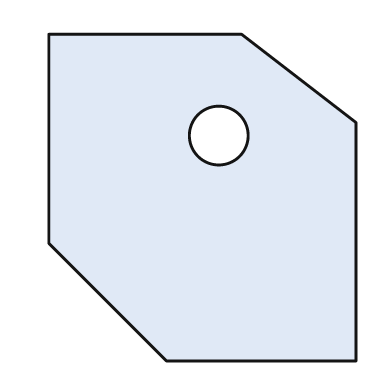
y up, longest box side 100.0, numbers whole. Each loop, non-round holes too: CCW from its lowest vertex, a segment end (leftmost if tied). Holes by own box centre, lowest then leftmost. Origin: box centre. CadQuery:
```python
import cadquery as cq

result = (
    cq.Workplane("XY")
    .moveTo(-11.0, -50.0)
    .lineTo(47.0, -50.0)
    .lineTo(47.0, 23.0)
    .lineTo(12.0, 50.0)
    .lineTo(-47.0, 50.0)
    .lineTo(-47.0, -14.0)
    .close()
    .moveTo(5.0, 19.0)
    .circle(9.0)
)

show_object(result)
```